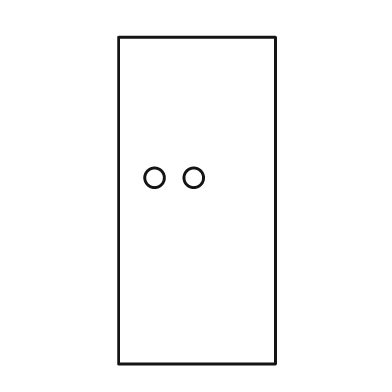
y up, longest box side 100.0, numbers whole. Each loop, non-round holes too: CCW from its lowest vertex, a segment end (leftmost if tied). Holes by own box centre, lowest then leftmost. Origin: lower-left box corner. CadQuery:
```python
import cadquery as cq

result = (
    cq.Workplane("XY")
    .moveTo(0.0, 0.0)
    .lineTo(48.0, 0.0)
    .lineTo(48.0, 100.0)
    .lineTo(0.0, 100.0)
    .close()
    .moveTo(11.0, 57.0)
    .circle(3.0)
    .moveTo(23.0, 57.0)
    .circle(3.0)
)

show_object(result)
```